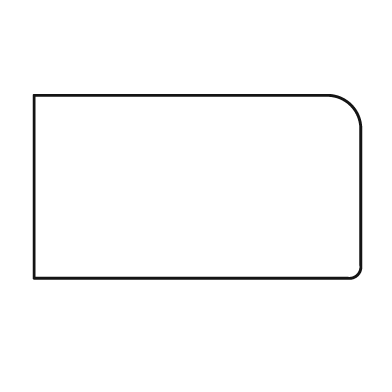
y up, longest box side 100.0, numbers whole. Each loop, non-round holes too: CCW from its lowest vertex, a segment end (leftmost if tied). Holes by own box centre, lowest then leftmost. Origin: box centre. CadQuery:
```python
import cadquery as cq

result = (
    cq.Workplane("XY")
    .moveTo(-50.0, -28.0)
    .lineTo(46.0, -28.0)
    .threePointArc((49.0, -27.0), (50.0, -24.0))
    .lineTo(50.0, 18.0)
    .threePointArc((47.0, 25.0), (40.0, 28.0))
    .lineTo(-50.0, 28.0)
    .close()
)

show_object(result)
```